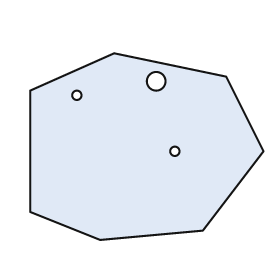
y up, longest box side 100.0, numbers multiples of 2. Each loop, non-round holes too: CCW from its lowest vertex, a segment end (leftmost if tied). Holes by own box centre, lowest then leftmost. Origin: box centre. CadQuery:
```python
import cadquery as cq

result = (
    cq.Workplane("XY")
    .moveTo(-20.0, -40.0)
    .lineTo(24.0, -36.0)
    .lineTo(50.0, -2.0)
    .lineTo(34.0, 30.0)
    .lineTo(-14.0, 40.0)
    .lineTo(-50.0, 24.0)
    .lineTo(-50.0, -28.0)
    .close()
    .moveTo(12.0, -2.0)
    .circle(2.0)
    .moveTo(-30.0, 22.0)
    .circle(2.0)
    .moveTo(4.0, 28.0)
    .circle(4.0)
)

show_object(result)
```